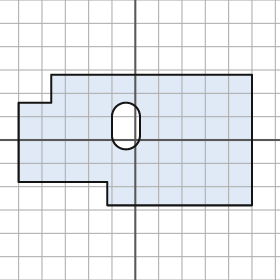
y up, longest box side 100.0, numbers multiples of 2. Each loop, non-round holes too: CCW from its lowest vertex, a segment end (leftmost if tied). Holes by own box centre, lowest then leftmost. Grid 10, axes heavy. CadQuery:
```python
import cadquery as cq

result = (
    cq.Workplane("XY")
    .moveTo(-12.0, -28.0)
    .lineTo(50.0, -28.0)
    .lineTo(50.0, 28.0)
    .lineTo(-36.0, 28.0)
    .lineTo(-36.0, 16.0)
    .lineTo(-50.0, 16.0)
    .lineTo(-50.0, -18.0)
    .lineTo(-12.0, -18.0)
    .close()
    .moveTo(-10.0, 2.0)
    .threePointArc((-4.0, -4.0), (2.0, 2.0))
    .lineTo(2.0, 10.0)
    .threePointArc((-4.0, 16.0), (-10.0, 10.0))
    .close()
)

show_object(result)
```